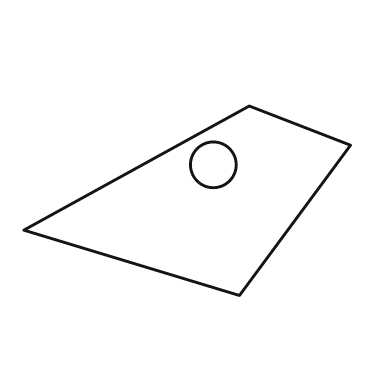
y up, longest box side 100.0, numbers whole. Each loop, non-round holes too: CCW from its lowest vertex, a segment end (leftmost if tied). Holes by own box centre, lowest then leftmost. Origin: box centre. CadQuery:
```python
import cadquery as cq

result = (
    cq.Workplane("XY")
    .moveTo(16.0, -29.0)
    .lineTo(50.0, 17.0)
    .lineTo(19.0, 29.0)
    .lineTo(-50.0, -9.0)
    .close()
    .moveTo(8.0, 11.0)
    .circle(7.0)
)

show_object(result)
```